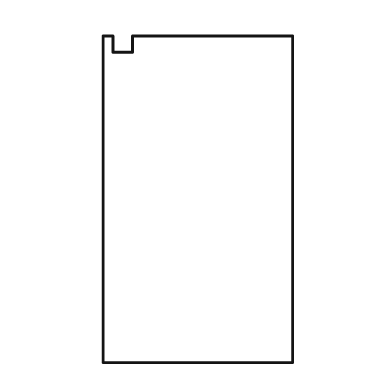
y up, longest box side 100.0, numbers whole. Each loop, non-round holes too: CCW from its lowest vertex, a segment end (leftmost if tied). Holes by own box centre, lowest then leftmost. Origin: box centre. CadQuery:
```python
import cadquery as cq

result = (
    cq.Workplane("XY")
    .moveTo(-29.0, -50.0)
    .lineTo(29.0, -50.0)
    .lineTo(29.0, 50.0)
    .lineTo(-20.0, 50.0)
    .lineTo(-20.0, 45.0)
    .lineTo(-26.0, 45.0)
    .lineTo(-26.0, 50.0)
    .lineTo(-29.0, 50.0)
    .close()
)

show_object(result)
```